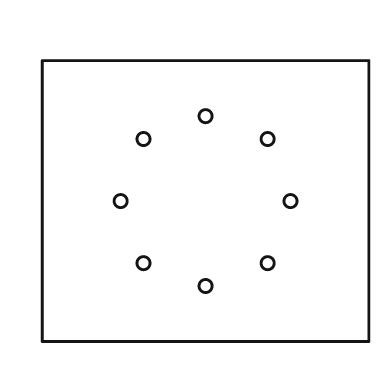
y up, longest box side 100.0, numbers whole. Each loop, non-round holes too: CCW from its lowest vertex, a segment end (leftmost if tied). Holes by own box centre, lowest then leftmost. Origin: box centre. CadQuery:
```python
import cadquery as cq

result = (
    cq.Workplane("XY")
    .moveTo(-50.0, -43.0)
    .lineTo(50.0, -43.0)
    .lineTo(50.0, 43.0)
    .lineTo(-50.0, 43.0)
    .close()
    .moveTo(0.0, -26.0)
    .circle(2.0)
    .moveTo(-19.0, -19.0)
    .circle(2.0)
    .moveTo(19.0, -19.0)
    .circle(2.0)
    .moveTo(-26.0, 0.0)
    .circle(2.0)
    .moveTo(26.0, 0.0)
    .circle(2.0)
    .moveTo(-19.0, 19.0)
    .circle(2.0)
    .moveTo(19.0, 19.0)
    .circle(2.0)
    .moveTo(0.0, 26.0)
    .circle(2.0)
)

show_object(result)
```